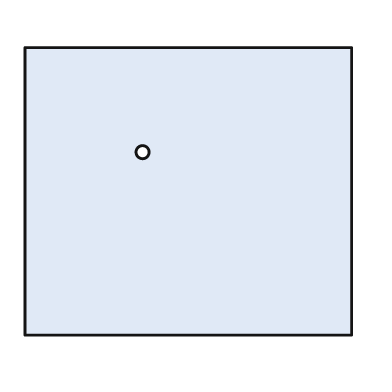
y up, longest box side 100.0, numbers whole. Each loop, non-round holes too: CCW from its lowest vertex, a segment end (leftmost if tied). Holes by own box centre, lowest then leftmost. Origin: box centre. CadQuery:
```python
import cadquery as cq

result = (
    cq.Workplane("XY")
    .moveTo(-50.0, -44.0)
    .lineTo(50.0, -44.0)
    .lineTo(50.0, 44.0)
    .lineTo(-50.0, 44.0)
    .close()
    .moveTo(-14.0, 12.0)
    .circle(2.0)
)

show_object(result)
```